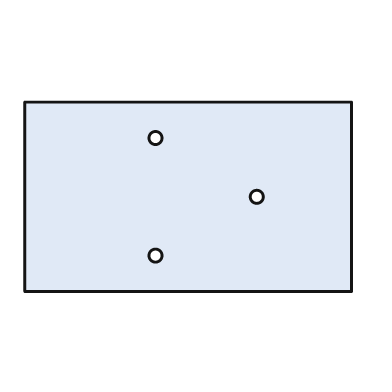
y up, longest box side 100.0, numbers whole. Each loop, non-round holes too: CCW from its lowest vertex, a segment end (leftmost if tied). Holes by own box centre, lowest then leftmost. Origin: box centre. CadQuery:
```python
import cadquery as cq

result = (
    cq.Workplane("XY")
    .moveTo(-50.0, -29.0)
    .lineTo(50.0, -29.0)
    .lineTo(50.0, 29.0)
    .lineTo(-50.0, 29.0)
    .close()
    .moveTo(-10.0, -18.0)
    .circle(2.0)
    .moveTo(21.0, 0.0)
    .circle(2.0)
    .moveTo(-10.0, 18.0)
    .circle(2.0)
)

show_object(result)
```